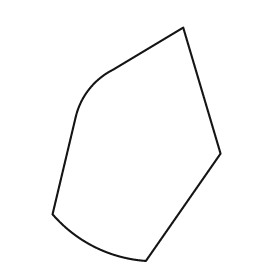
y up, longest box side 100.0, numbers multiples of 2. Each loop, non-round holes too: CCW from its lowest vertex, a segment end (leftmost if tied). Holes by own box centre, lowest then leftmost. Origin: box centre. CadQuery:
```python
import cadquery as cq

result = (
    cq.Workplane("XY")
    .moveTo(4.0, -50.0)
    .lineTo(36.0, -4.0)
    .lineTo(20.0, 50.0)
    .lineTo(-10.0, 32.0)
    .threePointArc((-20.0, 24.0), (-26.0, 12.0))
    .lineTo(-36.0, -30.0)
    .threePointArc((-18.0, -44.0), (4.0, -50.0))
    .close()
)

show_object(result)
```